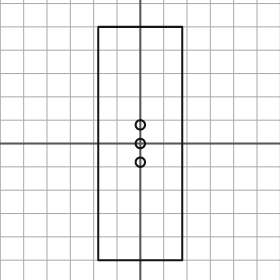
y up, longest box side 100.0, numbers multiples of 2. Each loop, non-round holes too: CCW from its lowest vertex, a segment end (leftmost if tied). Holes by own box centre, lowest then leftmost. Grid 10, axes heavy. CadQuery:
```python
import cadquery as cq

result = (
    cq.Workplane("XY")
    .moveTo(-18.0, -50.0)
    .lineTo(18.0, -50.0)
    .lineTo(18.0, 50.0)
    .lineTo(-18.0, 50.0)
    .close()
    .moveTo(0.0, -8.0)
    .circle(2.0)
    .moveTo(0.0, 0.0)
    .circle(2.0)
    .moveTo(0.0, 8.0)
    .circle(2.0)
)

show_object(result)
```